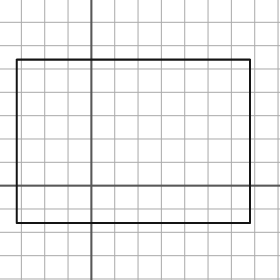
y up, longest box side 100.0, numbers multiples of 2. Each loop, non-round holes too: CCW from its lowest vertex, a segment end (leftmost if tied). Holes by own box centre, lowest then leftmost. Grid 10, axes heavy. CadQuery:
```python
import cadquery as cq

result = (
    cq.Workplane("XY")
    .moveTo(-32.0, -16.0)
    .lineTo(68.0, -16.0)
    .lineTo(68.0, 54.0)
    .lineTo(-32.0, 54.0)
    .close()
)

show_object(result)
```